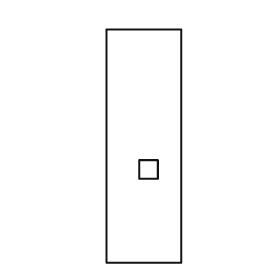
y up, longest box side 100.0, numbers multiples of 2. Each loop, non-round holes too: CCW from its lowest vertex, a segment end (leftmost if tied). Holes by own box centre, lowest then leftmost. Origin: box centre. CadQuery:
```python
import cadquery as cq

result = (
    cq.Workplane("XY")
    .moveTo(-16.0, -50.0)
    .lineTo(16.0, -50.0)
    .lineTo(16.0, 50.0)
    .lineTo(-16.0, 50.0)
    .close()
    .moveTo(-2.0, -14.0)
    .lineTo(6.0, -14.0)
    .lineTo(6.0, -6.0)
    .lineTo(-2.0, -6.0)
    .close()
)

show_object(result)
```